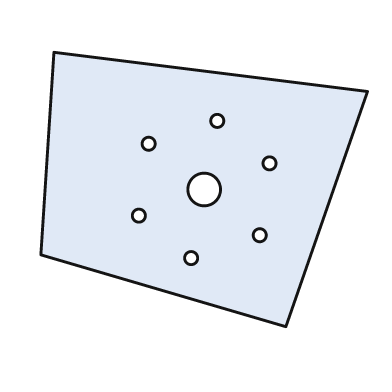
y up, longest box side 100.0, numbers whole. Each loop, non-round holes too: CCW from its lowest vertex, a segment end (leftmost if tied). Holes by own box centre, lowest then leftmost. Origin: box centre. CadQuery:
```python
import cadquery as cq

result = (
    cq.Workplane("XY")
    .moveTo(25.0, -42.0)
    .lineTo(50.0, 30.0)
    .lineTo(-46.0, 42.0)
    .lineTo(-50.0, -20.0)
    .close()
    .moveTo(-4.0, -21.0)
    .circle(2.0)
    .moveTo(17.0, -14.0)
    .circle(2.0)
    .moveTo(-20.0, -8.0)
    .circle(2.0)
    .moveTo(0.0, 0.0)
    .circle(5.0)
    .moveTo(20.0, 8.0)
    .circle(2.0)
    .moveTo(-17.0, 14.0)
    .circle(2.0)
    .moveTo(4.0, 21.0)
    .circle(2.0)
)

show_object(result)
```